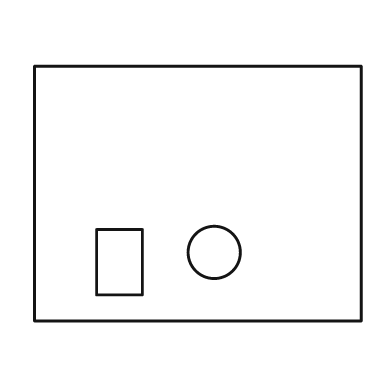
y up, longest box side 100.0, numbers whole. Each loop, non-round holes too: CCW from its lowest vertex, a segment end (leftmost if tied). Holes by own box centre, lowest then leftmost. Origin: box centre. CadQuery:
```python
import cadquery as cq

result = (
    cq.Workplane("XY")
    .moveTo(-50.0, -39.0)
    .lineTo(50.0, -39.0)
    .lineTo(50.0, 39.0)
    .lineTo(-50.0, 39.0)
    .close()
    .moveTo(-31.0, -31.0)
    .lineTo(-17.0, -31.0)
    .lineTo(-17.0, -11.0)
    .lineTo(-31.0, -11.0)
    .close()
    .moveTo(5.0, -18.0)
    .circle(8.0)
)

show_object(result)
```